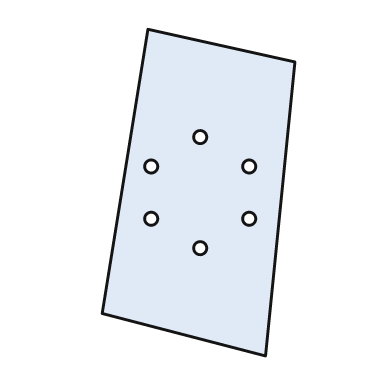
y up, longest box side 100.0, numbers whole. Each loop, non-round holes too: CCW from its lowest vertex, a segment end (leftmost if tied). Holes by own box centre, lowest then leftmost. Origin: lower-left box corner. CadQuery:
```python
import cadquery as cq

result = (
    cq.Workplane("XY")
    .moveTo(50.0, 0.0)
    .lineTo(59.0, 90.0)
    .lineTo(14.0, 100.0)
    .lineTo(0.0, 13.0)
    .close()
    .moveTo(30.0, 33.0)
    .circle(2.0)
    .moveTo(15.0, 42.0)
    .circle(2.0)
    .moveTo(45.0, 42.0)
    .circle(2.0)
    .moveTo(15.0, 58.0)
    .circle(2.0)
    .moveTo(45.0, 58.0)
    .circle(2.0)
    .moveTo(30.0, 67.0)
    .circle(2.0)
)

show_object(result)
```